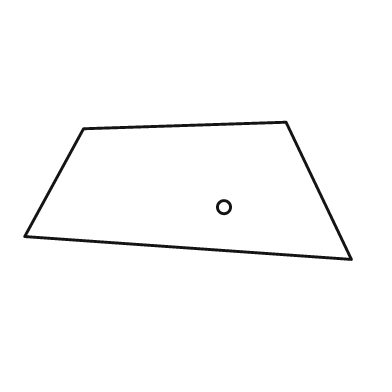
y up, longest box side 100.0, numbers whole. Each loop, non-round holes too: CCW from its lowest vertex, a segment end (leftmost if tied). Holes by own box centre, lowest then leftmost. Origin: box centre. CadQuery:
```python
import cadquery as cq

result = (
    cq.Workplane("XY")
    .moveTo(50.0, -21.0)
    .lineTo(30.0, 21.0)
    .lineTo(-32.0, 19.0)
    .lineTo(-50.0, -14.0)
    .close()
    .moveTo(11.0, -5.0)
    .circle(2.0)
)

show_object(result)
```